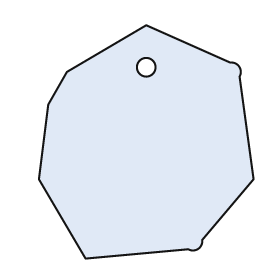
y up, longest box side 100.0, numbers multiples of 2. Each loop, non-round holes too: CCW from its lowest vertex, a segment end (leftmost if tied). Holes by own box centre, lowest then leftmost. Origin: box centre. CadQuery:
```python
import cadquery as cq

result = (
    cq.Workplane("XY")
    .moveTo(-26.0, -50.0)
    .lineTo(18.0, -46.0)
    .threePointArc((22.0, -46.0), (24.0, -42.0))
    .lineTo(46.0, -16.0)
    .lineTo(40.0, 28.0)
    .threePointArc((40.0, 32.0), (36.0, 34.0))
    .lineTo(0.0, 50.0)
    .lineTo(-34.0, 30.0)
    .lineTo(-42.0, 16.0)
    .lineTo(-46.0, -16.0)
    .close()
    .moveTo(0.0, 32.0)
    .circle(4.0)
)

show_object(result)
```